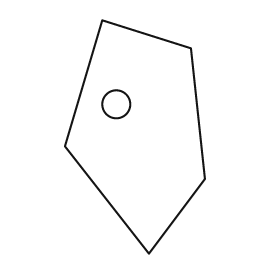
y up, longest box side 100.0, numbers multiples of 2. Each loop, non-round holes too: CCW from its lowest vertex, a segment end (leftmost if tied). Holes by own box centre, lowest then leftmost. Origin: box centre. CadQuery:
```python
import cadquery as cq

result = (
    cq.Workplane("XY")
    .moveTo(6.0, -50.0)
    .lineTo(30.0, -18.0)
    .lineTo(24.0, 38.0)
    .lineTo(-14.0, 50.0)
    .lineTo(-30.0, -4.0)
    .close()
    .moveTo(-8.0, 14.0)
    .circle(6.0)
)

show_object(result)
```